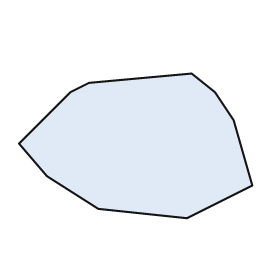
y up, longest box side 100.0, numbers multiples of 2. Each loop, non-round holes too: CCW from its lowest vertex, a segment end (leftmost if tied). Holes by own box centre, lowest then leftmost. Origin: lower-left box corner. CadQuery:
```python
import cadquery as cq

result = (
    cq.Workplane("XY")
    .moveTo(72.0, 0.0)
    .lineTo(100.0, 14.0)
    .lineTo(92.0, 42.0)
    .lineTo(84.0, 54.0)
    .lineTo(74.0, 62.0)
    .lineTo(30.0, 58.0)
    .lineTo(22.0, 54.0)
    .lineTo(0.0, 32.0)
    .lineTo(12.0, 18.0)
    .lineTo(34.0, 4.0)
    .close()
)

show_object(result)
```